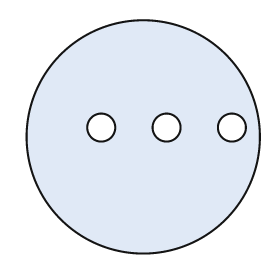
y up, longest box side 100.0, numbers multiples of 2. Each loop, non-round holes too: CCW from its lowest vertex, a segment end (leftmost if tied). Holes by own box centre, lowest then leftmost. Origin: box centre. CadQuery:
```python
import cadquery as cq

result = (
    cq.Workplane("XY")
    .moveTo(0.0, 0.0)
    .circle(50.0)
    .moveTo(-18.0, 4.0)
    .circle(6.0)
    .moveTo(10.0, 4.0)
    .circle(6.0)
    .moveTo(38.0, 4.0)
    .circle(6.0)
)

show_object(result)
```